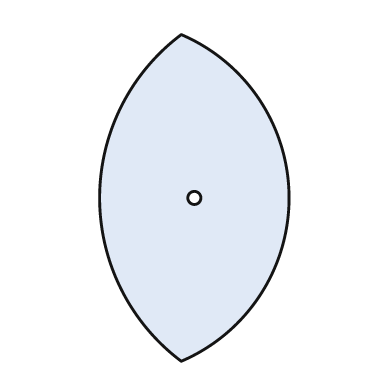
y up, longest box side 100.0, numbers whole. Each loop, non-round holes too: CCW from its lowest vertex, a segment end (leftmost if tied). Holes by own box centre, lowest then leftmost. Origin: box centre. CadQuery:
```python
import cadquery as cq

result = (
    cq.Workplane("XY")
    .moveTo(-4.0, -50.0)
    .threePointArc((29.0, 0.0), (-4.0, 50.0))
    .threePointArc((-29.0, 0.0), (-4.0, -50.0))
    .close()
    .moveTo(0.0, 0.0)
    .circle(2.0)
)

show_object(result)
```